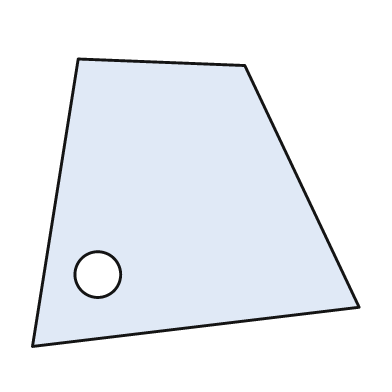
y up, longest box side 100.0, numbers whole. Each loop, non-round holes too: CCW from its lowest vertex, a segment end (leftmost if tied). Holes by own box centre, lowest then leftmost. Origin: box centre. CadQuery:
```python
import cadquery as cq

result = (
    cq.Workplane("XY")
    .moveTo(-50.0, -44.0)
    .lineTo(50.0, -32.0)
    .lineTo(15.0, 42.0)
    .lineTo(-36.0, 44.0)
    .close()
    .moveTo(-30.0, -22.0)
    .circle(7.0)
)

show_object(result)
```